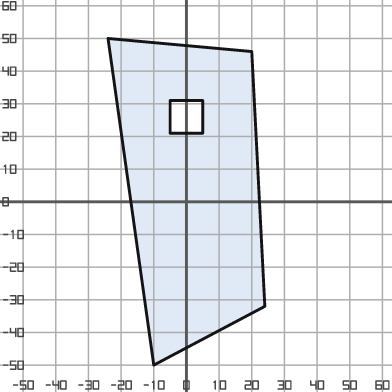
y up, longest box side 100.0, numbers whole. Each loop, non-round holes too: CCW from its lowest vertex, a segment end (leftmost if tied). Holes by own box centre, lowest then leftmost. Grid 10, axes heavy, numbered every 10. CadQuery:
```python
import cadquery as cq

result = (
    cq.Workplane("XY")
    .moveTo(-10.0, -50.0)
    .lineTo(24.0, -32.0)
    .lineTo(20.0, 46.0)
    .lineTo(-24.0, 50.0)
    .close()
    .moveTo(-5.0, 21.0)
    .lineTo(5.0, 21.0)
    .lineTo(5.0, 31.0)
    .lineTo(-5.0, 31.0)
    .close()
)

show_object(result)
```